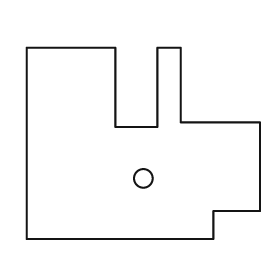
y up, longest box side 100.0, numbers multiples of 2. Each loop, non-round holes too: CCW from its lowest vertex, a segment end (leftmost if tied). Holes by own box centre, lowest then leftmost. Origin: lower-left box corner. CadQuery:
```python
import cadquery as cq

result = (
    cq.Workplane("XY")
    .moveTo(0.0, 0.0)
    .lineTo(80.0, 0.0)
    .lineTo(80.0, 12.0)
    .lineTo(100.0, 12.0)
    .lineTo(100.0, 50.0)
    .lineTo(66.0, 50.0)
    .lineTo(66.0, 82.0)
    .lineTo(56.0, 82.0)
    .lineTo(56.0, 48.0)
    .lineTo(38.0, 48.0)
    .lineTo(38.0, 82.0)
    .lineTo(0.0, 82.0)
    .close()
    .moveTo(50.0, 26.0)
    .circle(4.0)
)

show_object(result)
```